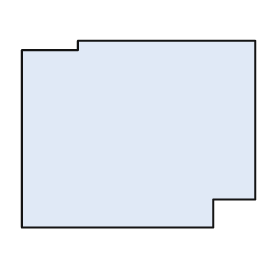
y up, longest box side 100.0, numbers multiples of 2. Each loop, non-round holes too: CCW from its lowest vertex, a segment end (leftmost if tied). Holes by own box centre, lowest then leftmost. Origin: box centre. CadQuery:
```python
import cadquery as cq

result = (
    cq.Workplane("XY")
    .moveTo(-50.0, -40.0)
    .lineTo(32.0, -40.0)
    .lineTo(32.0, -28.0)
    .lineTo(50.0, -28.0)
    .lineTo(50.0, 40.0)
    .lineTo(-26.0, 40.0)
    .lineTo(-26.0, 36.0)
    .lineTo(-50.0, 36.0)
    .close()
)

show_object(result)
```